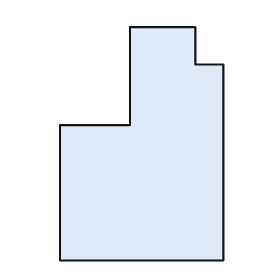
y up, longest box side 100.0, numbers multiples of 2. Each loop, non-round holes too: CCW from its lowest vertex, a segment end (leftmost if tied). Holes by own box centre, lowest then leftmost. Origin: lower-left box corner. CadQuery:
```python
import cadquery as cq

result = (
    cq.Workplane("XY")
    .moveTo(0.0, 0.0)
    .lineTo(70.0, 0.0)
    .lineTo(70.0, 84.0)
    .lineTo(58.0, 84.0)
    .lineTo(58.0, 100.0)
    .lineTo(30.0, 100.0)
    .lineTo(30.0, 58.0)
    .lineTo(0.0, 58.0)
    .close()
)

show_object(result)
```